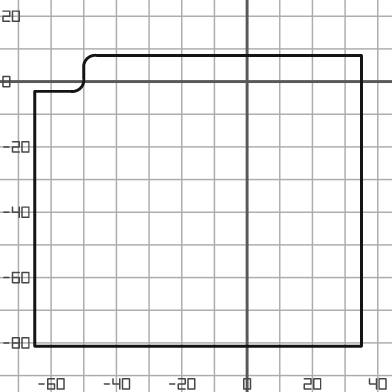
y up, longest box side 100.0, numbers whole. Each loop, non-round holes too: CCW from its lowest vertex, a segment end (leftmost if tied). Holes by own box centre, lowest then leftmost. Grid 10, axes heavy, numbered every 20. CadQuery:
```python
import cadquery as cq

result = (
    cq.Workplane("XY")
    .moveTo(-65.0, -81.0)
    .lineTo(35.0, -81.0)
    .lineTo(35.0, 8.0)
    .lineTo(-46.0, 8.0)
    .threePointArc((-49.0, 7.0), (-50.0, 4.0))
    .lineTo(-50.0, 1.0)
    .threePointArc((-51.0, -2.0), (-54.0, -3.0))
    .lineTo(-65.0, -3.0)
    .close()
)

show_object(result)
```